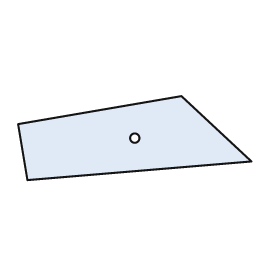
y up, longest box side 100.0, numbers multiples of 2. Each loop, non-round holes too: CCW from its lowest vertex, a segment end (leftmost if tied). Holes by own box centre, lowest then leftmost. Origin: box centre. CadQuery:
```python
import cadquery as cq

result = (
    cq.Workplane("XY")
    .moveTo(-46.0, -18.0)
    .lineTo(50.0, -10.0)
    .lineTo(20.0, 18.0)
    .lineTo(-50.0, 6.0)
    .close()
    .moveTo(0.0, 0.0)
    .circle(2.0)
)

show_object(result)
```